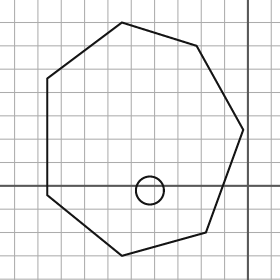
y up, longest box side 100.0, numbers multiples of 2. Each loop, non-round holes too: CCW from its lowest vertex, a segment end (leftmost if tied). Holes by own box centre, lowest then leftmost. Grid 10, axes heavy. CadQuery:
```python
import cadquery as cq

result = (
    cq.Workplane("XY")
    .moveTo(-54.0, -30.0)
    .lineTo(-18.0, -20.0)
    .lineTo(-2.0, 24.0)
    .lineTo(-22.0, 60.0)
    .lineTo(-54.0, 70.0)
    .lineTo(-86.0, 46.0)
    .lineTo(-86.0, -4.0)
    .close()
    .moveTo(-42.0, -2.0)
    .circle(6.0)
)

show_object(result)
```